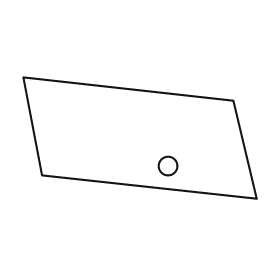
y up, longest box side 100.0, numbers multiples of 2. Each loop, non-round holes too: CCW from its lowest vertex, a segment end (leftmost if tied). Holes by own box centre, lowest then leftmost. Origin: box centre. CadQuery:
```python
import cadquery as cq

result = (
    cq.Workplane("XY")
    .moveTo(50.0, -26.0)
    .lineTo(40.0, 16.0)
    .lineTo(-50.0, 26.0)
    .lineTo(-42.0, -16.0)
    .close()
    .moveTo(12.0, -12.0)
    .circle(4.0)
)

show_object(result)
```